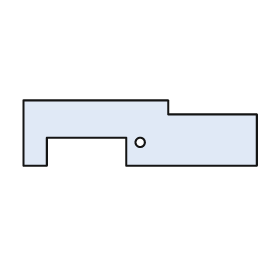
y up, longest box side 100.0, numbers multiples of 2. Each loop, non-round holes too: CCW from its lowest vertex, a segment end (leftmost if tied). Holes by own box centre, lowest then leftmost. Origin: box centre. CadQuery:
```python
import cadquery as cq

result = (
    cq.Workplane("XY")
    .moveTo(-50.0, -14.0)
    .lineTo(-40.0, -14.0)
    .lineTo(-40.0, -2.0)
    .lineTo(-6.0, -2.0)
    .lineTo(-6.0, -14.0)
    .lineTo(50.0, -14.0)
    .lineTo(50.0, 8.0)
    .lineTo(12.0, 8.0)
    .lineTo(12.0, 14.0)
    .lineTo(-50.0, 14.0)
    .close()
    .moveTo(0.0, -4.0)
    .circle(2.0)
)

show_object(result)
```